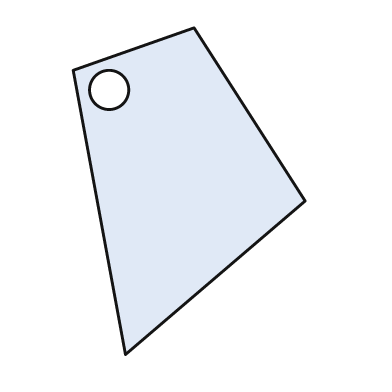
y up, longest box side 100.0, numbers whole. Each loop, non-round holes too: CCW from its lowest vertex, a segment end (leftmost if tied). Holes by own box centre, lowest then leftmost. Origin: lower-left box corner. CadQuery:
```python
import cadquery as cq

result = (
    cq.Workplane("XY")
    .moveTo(16.0, 0.0)
    .lineTo(71.0, 47.0)
    .lineTo(37.0, 100.0)
    .lineTo(0.0, 87.0)
    .close()
    .moveTo(11.0, 81.0)
    .circle(6.0)
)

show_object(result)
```